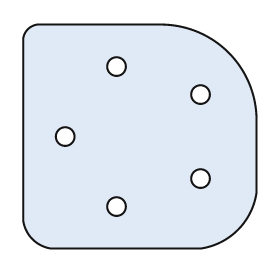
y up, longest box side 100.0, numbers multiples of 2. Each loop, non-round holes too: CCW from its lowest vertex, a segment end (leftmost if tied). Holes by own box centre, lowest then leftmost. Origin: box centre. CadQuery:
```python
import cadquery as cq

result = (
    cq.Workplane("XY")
    .moveTo(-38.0, -48.0)
    .lineTo(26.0, -48.0)
    .threePointArc((42.0, -40.0), (50.0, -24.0))
    .lineTo(50.0, 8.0)
    .threePointArc((38.0, 36.0), (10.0, 48.0))
    .lineTo(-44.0, 48.0)
    .threePointArc((-48.0, 46.0), (-50.0, 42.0))
    .lineTo(-50.0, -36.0)
    .threePointArc((-46.0, -44.0), (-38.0, -48.0))
    .close()
    .moveTo(-10.0, -30.0)
    .circle(4.0)
    .moveTo(26.0, -18.0)
    .circle(4.0)
    .moveTo(-32.0, 0.0)
    .circle(4.0)
    .moveTo(26.0, 18.0)
    .circle(4.0)
    .moveTo(-10.0, 30.0)
    .circle(4.0)
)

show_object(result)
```